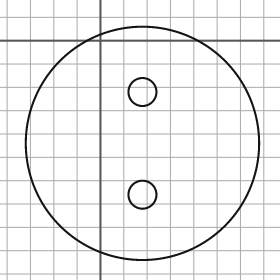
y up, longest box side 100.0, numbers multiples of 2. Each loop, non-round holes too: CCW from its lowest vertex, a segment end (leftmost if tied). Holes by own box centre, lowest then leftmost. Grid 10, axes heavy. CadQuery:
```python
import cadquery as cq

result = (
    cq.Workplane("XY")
    .moveTo(18.0, -44.0)
    .circle(50.0)
    .moveTo(18.0, -66.0)
    .circle(6.0)
    .moveTo(18.0, -22.0)
    .circle(6.0)
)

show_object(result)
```